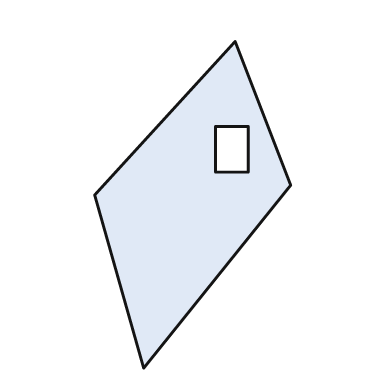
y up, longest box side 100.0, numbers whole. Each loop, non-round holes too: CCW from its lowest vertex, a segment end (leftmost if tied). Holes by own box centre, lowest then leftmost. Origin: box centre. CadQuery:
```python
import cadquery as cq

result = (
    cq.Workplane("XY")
    .moveTo(-15.0, -50.0)
    .lineTo(30.0, 6.0)
    .lineTo(13.0, 50.0)
    .lineTo(-30.0, 3.0)
    .close()
    .moveTo(7.0, 10.0)
    .lineTo(17.0, 10.0)
    .lineTo(17.0, 24.0)
    .lineTo(7.0, 24.0)
    .close()
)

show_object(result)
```